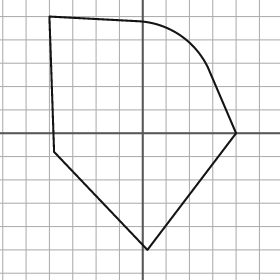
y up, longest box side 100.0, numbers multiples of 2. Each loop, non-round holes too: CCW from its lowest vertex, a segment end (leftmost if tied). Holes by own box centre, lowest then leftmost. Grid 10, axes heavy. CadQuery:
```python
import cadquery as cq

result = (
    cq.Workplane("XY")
    .moveTo(2.0, -50.0)
    .lineTo(40.0, 0.0)
    .lineTo(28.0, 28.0)
    .threePointArc((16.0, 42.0), (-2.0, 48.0))
    .lineTo(-40.0, 50.0)
    .lineTo(-38.0, -8.0)
    .close()
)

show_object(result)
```